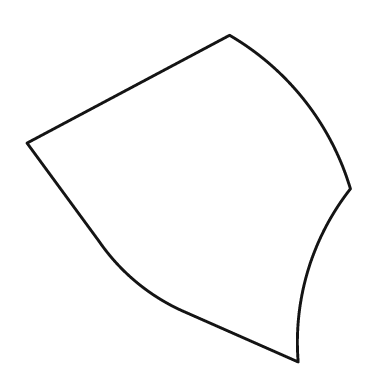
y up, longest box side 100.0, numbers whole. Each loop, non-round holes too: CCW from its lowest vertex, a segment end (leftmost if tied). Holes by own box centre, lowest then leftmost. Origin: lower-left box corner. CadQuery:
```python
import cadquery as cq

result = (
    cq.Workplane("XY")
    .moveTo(83.0, 0.0)
    .threePointArc((86.0, 28.0), (99.0, 53.0))
    .threePointArc((85.0, 80.0), (62.0, 100.0))
    .lineTo(0.0, 67.0)
    .lineTo(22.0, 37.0)
    .threePointArc((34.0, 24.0), (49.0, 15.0))
    .close()
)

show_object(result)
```